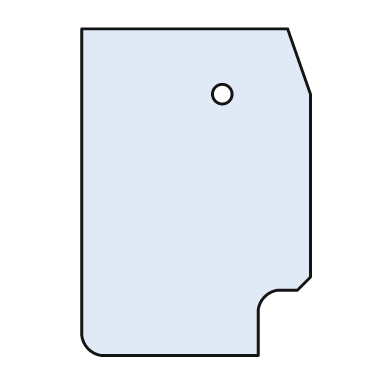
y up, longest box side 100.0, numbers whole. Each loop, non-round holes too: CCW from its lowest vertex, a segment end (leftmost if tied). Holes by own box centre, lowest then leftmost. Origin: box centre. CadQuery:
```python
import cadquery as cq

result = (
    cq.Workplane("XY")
    .moveTo(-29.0, -50.0)
    .lineTo(19.0, -50.0)
    .lineTo(19.0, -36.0)
    .threePointArc((21.0, -32.0), (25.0, -30.0))
    .lineTo(31.0, -30.0)
    .lineTo(35.0, -26.0)
    .lineTo(35.0, 30.0)
    .lineTo(28.0, 50.0)
    .lineTo(-35.0, 50.0)
    .lineTo(-35.0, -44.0)
    .threePointArc((-33.0, -48.0), (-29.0, -50.0))
    .close()
    .moveTo(8.0, 30.0)
    .circle(3.0)
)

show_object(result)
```